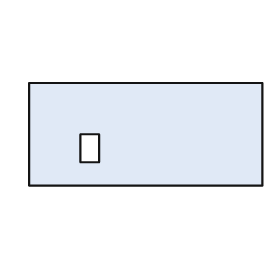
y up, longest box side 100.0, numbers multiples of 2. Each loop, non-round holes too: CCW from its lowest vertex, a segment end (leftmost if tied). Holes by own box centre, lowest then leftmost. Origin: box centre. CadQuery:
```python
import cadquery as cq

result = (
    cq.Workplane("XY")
    .moveTo(-50.0, -22.0)
    .lineTo(50.0, -22.0)
    .lineTo(50.0, 22.0)
    .lineTo(-50.0, 22.0)
    .close()
    .moveTo(-28.0, -12.0)
    .lineTo(-20.0, -12.0)
    .lineTo(-20.0, 0.0)
    .lineTo(-28.0, 0.0)
    .close()
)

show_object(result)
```